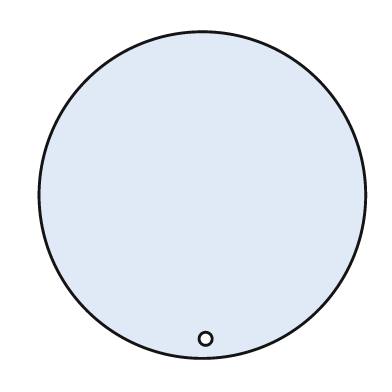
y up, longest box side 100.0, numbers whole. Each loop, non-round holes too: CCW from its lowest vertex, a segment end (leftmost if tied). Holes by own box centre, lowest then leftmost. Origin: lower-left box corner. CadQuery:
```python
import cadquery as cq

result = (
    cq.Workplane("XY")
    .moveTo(50.0, 50.0)
    .circle(50.0)
    .moveTo(51.0, 6.0)
    .circle(2.0)
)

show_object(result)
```